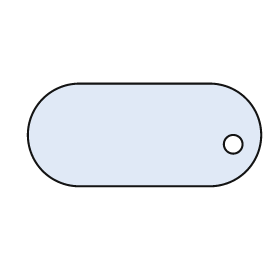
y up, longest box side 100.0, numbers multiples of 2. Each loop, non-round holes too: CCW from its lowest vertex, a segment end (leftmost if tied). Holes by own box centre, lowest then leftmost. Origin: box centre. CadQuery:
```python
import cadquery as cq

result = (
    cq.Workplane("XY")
    .moveTo(-28.0, -22.0)
    .lineTo(28.0, -22.0)
    .threePointArc((50.0, 0.0), (28.0, 22.0))
    .lineTo(-28.0, 22.0)
    .threePointArc((-50.0, 0.0), (-28.0, -22.0))
    .close()
    .moveTo(38.0, -4.0)
    .circle(4.0)
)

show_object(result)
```